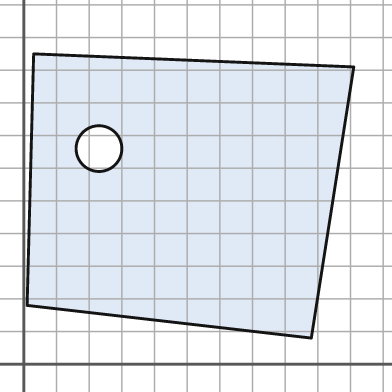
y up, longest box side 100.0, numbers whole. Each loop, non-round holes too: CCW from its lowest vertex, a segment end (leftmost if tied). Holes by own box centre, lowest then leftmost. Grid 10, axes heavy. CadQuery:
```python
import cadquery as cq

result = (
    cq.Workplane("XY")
    .moveTo(88.0, 8.0)
    .lineTo(101.0, 91.0)
    .lineTo(3.0, 95.0)
    .lineTo(1.0, 18.0)
    .close()
    .moveTo(23.0, 66.0)
    .circle(7.0)
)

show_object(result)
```